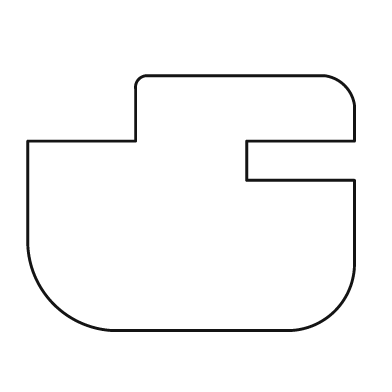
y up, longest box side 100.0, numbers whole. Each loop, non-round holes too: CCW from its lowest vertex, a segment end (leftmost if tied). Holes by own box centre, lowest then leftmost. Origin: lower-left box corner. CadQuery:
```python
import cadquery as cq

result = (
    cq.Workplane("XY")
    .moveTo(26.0, 0.0)
    .lineTo(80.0, 0.0)
    .threePointArc((94.0, 6.0), (100.0, 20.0))
    .lineTo(100.0, 46.0)
    .lineTo(67.0, 46.0)
    .lineTo(67.0, 58.0)
    .lineTo(100.0, 58.0)
    .lineTo(100.0, 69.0)
    .threePointArc((97.0, 75.0), (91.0, 78.0))
    .lineTo(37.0, 78.0)
    .threePointArc((34.0, 77.0), (33.0, 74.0))
    .lineTo(33.0, 58.0)
    .lineTo(0.0, 58.0)
    .lineTo(0.0, 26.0)
    .threePointArc((8.0, 8.0), (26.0, 0.0))
    .close()
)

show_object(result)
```